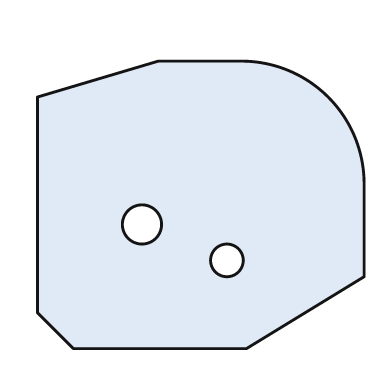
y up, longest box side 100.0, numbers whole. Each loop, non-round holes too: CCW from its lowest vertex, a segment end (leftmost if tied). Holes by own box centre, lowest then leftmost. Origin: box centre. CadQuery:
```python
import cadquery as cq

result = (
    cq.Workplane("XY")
    .moveTo(-39.0, -44.0)
    .lineTo(14.0, -44.0)
    .lineTo(50.0, -22.0)
    .lineTo(50.0, 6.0)
    .threePointArc((39.0, 33.0), (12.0, 44.0))
    .lineTo(-13.0, 44.0)
    .lineTo(-50.0, 33.0)
    .lineTo(-50.0, -33.0)
    .close()
    .moveTo(8.0, -17.0)
    .circle(5.0)
    .moveTo(-18.0, -6.0)
    .circle(6.0)
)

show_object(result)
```